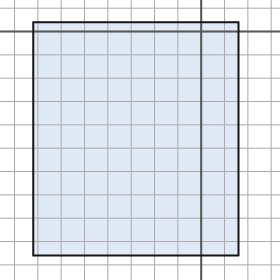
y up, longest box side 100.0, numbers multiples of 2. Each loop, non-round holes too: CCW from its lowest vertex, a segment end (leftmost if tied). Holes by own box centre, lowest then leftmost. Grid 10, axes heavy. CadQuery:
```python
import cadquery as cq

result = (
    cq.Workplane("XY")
    .moveTo(-72.0, -96.0)
    .lineTo(16.0, -96.0)
    .lineTo(16.0, 4.0)
    .lineTo(-72.0, 4.0)
    .close()
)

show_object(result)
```